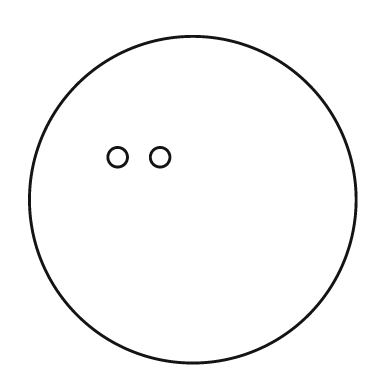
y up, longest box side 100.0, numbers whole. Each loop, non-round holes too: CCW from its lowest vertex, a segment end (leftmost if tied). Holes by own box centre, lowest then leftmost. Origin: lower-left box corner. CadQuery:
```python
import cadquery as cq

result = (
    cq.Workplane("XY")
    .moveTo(50.0, 50.0)
    .circle(50.0)
    .moveTo(27.0, 63.0)
    .circle(3.0)
    .moveTo(40.0, 63.0)
    .circle(3.0)
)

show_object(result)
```